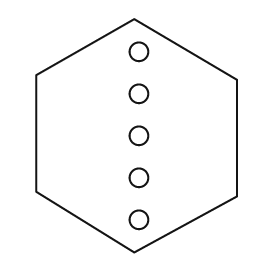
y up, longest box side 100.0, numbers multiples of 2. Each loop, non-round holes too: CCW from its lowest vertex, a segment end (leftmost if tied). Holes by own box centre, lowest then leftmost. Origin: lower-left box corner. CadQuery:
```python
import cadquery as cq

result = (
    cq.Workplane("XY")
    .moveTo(42.0, 0.0)
    .lineTo(86.0, 24.0)
    .lineTo(86.0, 74.0)
    .lineTo(42.0, 100.0)
    .lineTo(0.0, 76.0)
    .lineTo(0.0, 26.0)
    .close()
    .moveTo(44.0, 14.0)
    .circle(4.0)
    .moveTo(44.0, 32.0)
    .circle(4.0)
    .moveTo(44.0, 50.0)
    .circle(4.0)
    .moveTo(44.0, 68.0)
    .circle(4.0)
    .moveTo(44.0, 86.0)
    .circle(4.0)
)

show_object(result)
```